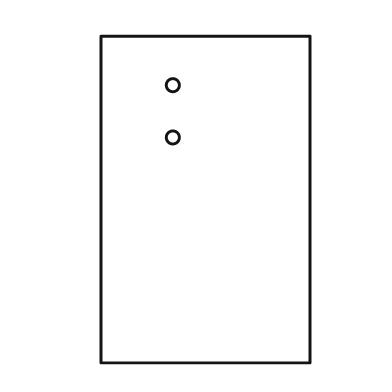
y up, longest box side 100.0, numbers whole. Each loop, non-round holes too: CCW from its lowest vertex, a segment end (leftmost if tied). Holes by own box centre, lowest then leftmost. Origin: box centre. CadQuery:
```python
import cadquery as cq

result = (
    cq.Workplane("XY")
    .moveTo(-32.0, -50.0)
    .lineTo(32.0, -50.0)
    .lineTo(32.0, 50.0)
    .lineTo(-32.0, 50.0)
    .close()
    .moveTo(-10.0, 19.0)
    .circle(2.0)
    .moveTo(-10.0, 35.0)
    .circle(2.0)
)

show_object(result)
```